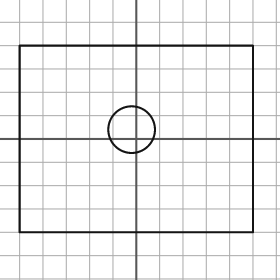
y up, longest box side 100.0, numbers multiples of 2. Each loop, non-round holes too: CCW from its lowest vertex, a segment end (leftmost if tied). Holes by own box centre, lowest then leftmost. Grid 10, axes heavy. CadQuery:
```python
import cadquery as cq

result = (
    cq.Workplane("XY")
    .moveTo(-50.0, -40.0)
    .lineTo(50.0, -40.0)
    .lineTo(50.0, 40.0)
    .lineTo(-50.0, 40.0)
    .close()
    .moveTo(-2.0, 4.0)
    .circle(10.0)
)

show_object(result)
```